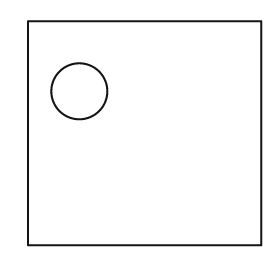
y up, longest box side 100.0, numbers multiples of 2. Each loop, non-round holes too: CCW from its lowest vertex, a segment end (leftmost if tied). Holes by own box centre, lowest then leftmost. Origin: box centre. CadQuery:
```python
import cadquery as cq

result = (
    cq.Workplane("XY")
    .moveTo(-50.0, -48.0)
    .lineTo(50.0, -48.0)
    .lineTo(50.0, 48.0)
    .lineTo(-50.0, 48.0)
    .close()
    .moveTo(-28.0, 18.0)
    .circle(12.0)
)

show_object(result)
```